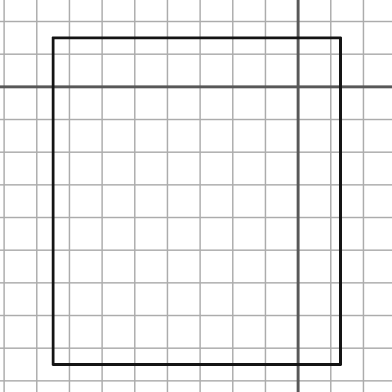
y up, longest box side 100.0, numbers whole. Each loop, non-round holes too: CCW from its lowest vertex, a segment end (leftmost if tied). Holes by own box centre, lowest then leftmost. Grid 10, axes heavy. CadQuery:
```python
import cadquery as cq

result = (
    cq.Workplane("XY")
    .moveTo(-75.0, -85.0)
    .lineTo(13.0, -85.0)
    .lineTo(13.0, 15.0)
    .lineTo(-75.0, 15.0)
    .close()
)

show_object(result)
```